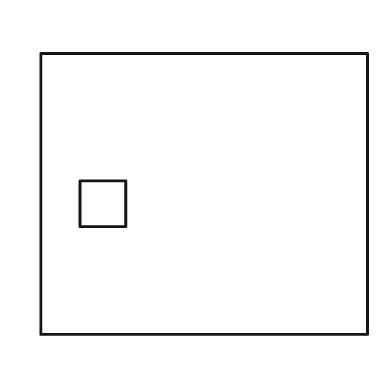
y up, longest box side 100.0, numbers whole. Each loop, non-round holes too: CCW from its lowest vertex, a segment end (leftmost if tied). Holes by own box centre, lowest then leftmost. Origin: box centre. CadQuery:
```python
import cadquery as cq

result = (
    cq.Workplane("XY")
    .moveTo(-50.0, -43.0)
    .lineTo(50.0, -43.0)
    .lineTo(50.0, 43.0)
    .lineTo(-50.0, 43.0)
    .close()
    .moveTo(-38.0, -10.0)
    .lineTo(-24.0, -10.0)
    .lineTo(-24.0, 4.0)
    .lineTo(-38.0, 4.0)
    .close()
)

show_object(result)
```